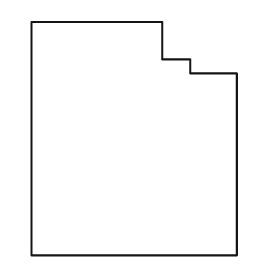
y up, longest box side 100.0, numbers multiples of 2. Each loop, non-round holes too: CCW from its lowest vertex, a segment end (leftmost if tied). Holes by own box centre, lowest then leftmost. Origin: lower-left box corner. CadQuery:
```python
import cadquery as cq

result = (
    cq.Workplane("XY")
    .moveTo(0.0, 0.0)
    .lineTo(88.0, 0.0)
    .lineTo(88.0, 78.0)
    .lineTo(68.0, 78.0)
    .lineTo(68.0, 84.0)
    .lineTo(56.0, 84.0)
    .lineTo(56.0, 100.0)
    .lineTo(0.0, 100.0)
    .close()
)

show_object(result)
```